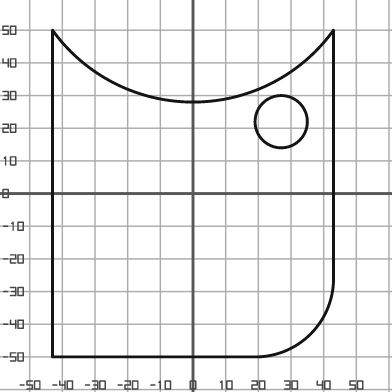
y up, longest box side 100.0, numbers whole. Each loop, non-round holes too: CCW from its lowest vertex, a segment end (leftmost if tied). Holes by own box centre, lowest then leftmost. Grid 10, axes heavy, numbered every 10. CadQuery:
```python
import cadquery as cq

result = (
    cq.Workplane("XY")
    .moveTo(-43.0, -50.0)
    .lineTo(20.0, -50.0)
    .threePointArc((36.0, -43.0), (43.0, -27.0))
    .lineTo(43.0, 50.0)
    .threePointArc((0.0, 28.0), (-43.0, 50.0))
    .close()
    .moveTo(27.0, 22.0)
    .circle(8.0)
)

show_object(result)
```